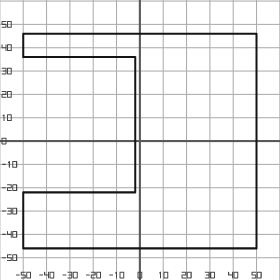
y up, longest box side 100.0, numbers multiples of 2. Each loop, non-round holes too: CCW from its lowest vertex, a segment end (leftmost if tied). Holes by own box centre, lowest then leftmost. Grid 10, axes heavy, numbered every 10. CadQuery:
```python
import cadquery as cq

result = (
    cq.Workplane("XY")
    .moveTo(-50.0, -46.0)
    .lineTo(50.0, -46.0)
    .lineTo(50.0, 46.0)
    .lineTo(-50.0, 46.0)
    .lineTo(-50.0, 36.0)
    .lineTo(-2.0, 36.0)
    .lineTo(-2.0, -22.0)
    .lineTo(-50.0, -22.0)
    .close()
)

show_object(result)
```